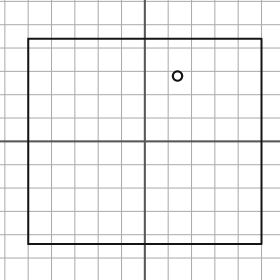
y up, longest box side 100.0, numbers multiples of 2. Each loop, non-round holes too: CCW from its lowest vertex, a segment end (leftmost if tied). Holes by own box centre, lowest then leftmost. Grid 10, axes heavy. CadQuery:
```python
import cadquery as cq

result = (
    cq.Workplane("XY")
    .moveTo(-50.0, -44.0)
    .lineTo(50.0, -44.0)
    .lineTo(50.0, 44.0)
    .lineTo(-50.0, 44.0)
    .close()
    .moveTo(14.0, 28.0)
    .circle(2.0)
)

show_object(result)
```